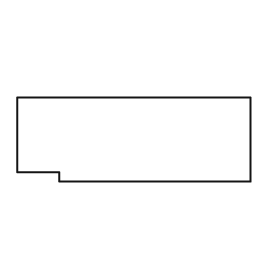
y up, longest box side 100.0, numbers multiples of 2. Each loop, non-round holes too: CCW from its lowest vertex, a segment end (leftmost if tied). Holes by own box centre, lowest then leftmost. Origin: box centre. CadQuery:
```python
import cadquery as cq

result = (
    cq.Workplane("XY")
    .moveTo(-32.0, -18.0)
    .lineTo(50.0, -18.0)
    .lineTo(50.0, 18.0)
    .lineTo(-50.0, 18.0)
    .lineTo(-50.0, -14.0)
    .lineTo(-32.0, -14.0)
    .close()
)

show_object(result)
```